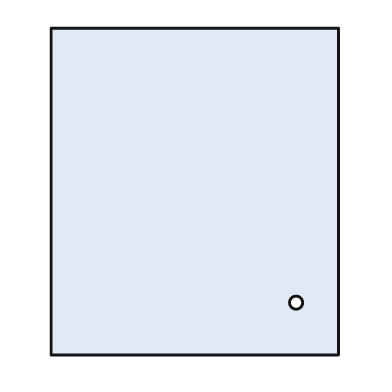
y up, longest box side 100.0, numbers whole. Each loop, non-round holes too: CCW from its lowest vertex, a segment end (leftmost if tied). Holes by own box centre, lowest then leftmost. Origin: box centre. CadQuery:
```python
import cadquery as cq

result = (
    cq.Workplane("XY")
    .moveTo(-44.0, -50.0)
    .lineTo(44.0, -50.0)
    .lineTo(44.0, 50.0)
    .lineTo(-44.0, 50.0)
    .close()
    .moveTo(31.0, -34.0)
    .circle(2.0)
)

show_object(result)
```